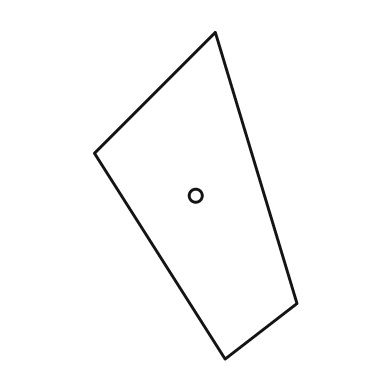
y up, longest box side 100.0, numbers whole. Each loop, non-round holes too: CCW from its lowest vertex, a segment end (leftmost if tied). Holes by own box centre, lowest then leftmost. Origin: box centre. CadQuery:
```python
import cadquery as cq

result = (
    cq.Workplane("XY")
    .moveTo(9.0, -50.0)
    .lineTo(31.0, -33.0)
    .lineTo(6.0, 50.0)
    .lineTo(-31.0, 13.0)
    .close()
    .moveTo(0.0, 0.0)
    .circle(2.0)
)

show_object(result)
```